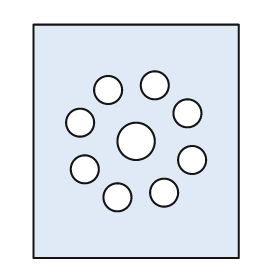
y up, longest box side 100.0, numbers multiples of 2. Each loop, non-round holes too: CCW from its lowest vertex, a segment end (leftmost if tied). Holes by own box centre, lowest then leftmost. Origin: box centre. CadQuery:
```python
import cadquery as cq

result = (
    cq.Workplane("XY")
    .moveTo(-44.0, -50.0)
    .lineTo(44.0, -50.0)
    .lineTo(44.0, 50.0)
    .lineTo(-44.0, 50.0)
    .close()
    .moveTo(-8.0, -24.0)
    .circle(6.0)
    .moveTo(12.0, -22.0)
    .circle(6.0)
    .moveTo(-22.0, -12.0)
    .circle(6.0)
    .moveTo(24.0, -8.0)
    .circle(6.0)
    .moveTo(0.0, 0.0)
    .circle(8.0)
    .moveTo(-24.0, 8.0)
    .circle(6.0)
    .moveTo(22.0, 12.0)
    .circle(6.0)
    .moveTo(-12.0, 22.0)
    .circle(6.0)
    .moveTo(8.0, 24.0)
    .circle(6.0)
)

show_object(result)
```